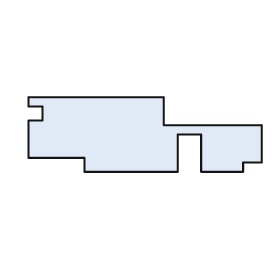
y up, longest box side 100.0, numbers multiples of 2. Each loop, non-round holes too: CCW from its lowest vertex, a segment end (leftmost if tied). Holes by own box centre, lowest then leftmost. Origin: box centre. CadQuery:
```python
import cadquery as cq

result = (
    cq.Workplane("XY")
    .moveTo(-26.0, -16.0)
    .lineTo(14.0, -16.0)
    .lineTo(14.0, 0.0)
    .lineTo(24.0, 0.0)
    .lineTo(24.0, -16.0)
    .lineTo(42.0, -16.0)
    .lineTo(42.0, -12.0)
    .lineTo(50.0, -12.0)
    .lineTo(50.0, 4.0)
    .lineTo(8.0, 4.0)
    .lineTo(8.0, 16.0)
    .lineTo(-50.0, 16.0)
    .lineTo(-50.0, 12.0)
    .lineTo(-44.0, 12.0)
    .lineTo(-44.0, 6.0)
    .lineTo(-50.0, 6.0)
    .lineTo(-50.0, -10.0)
    .lineTo(-26.0, -10.0)
    .close()
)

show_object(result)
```